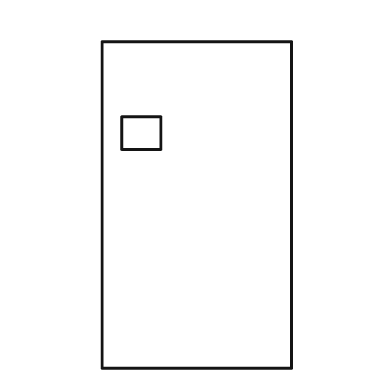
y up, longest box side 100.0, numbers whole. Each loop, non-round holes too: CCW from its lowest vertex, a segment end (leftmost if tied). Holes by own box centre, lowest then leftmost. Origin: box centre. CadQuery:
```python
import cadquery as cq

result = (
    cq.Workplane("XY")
    .moveTo(-29.0, -50.0)
    .lineTo(29.0, -50.0)
    .lineTo(29.0, 50.0)
    .lineTo(-29.0, 50.0)
    .close()
    .moveTo(-23.0, 17.0)
    .lineTo(-11.0, 17.0)
    .lineTo(-11.0, 27.0)
    .lineTo(-23.0, 27.0)
    .close()
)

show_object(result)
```